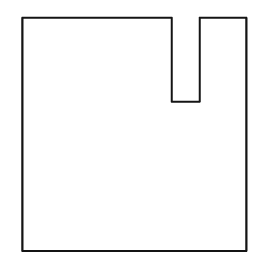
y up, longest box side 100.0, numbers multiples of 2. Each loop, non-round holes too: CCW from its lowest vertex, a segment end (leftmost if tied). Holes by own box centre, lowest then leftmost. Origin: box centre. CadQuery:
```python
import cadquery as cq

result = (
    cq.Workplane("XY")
    .moveTo(-48.0, -50.0)
    .lineTo(48.0, -50.0)
    .lineTo(48.0, 50.0)
    .lineTo(28.0, 50.0)
    .lineTo(28.0, 14.0)
    .lineTo(16.0, 14.0)
    .lineTo(16.0, 50.0)
    .lineTo(-48.0, 50.0)
    .close()
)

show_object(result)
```